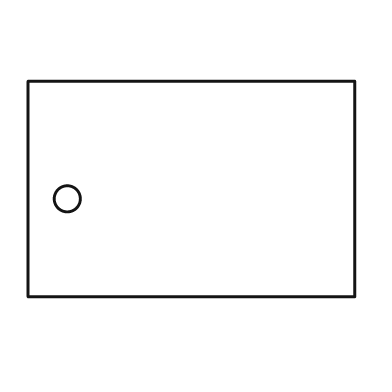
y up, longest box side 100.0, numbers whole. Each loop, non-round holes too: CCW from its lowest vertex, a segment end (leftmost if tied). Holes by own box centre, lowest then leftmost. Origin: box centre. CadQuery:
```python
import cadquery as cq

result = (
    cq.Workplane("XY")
    .moveTo(-50.0, -33.0)
    .lineTo(50.0, -33.0)
    .lineTo(50.0, 33.0)
    .lineTo(-50.0, 33.0)
    .close()
    .moveTo(-38.0, -3.0)
    .circle(4.0)
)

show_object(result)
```